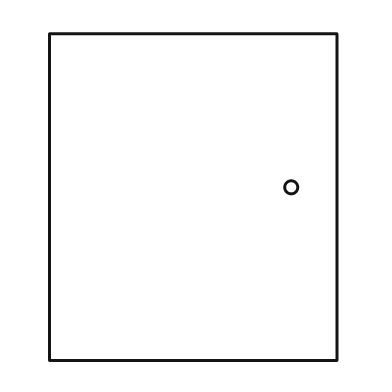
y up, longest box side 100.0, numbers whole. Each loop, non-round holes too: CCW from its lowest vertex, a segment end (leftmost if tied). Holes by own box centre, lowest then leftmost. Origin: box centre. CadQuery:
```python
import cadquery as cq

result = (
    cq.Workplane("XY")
    .moveTo(-44.0, -50.0)
    .lineTo(44.0, -50.0)
    .lineTo(44.0, 50.0)
    .lineTo(-44.0, 50.0)
    .close()
    .moveTo(30.0, 3.0)
    .circle(2.0)
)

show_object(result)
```